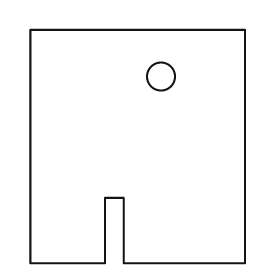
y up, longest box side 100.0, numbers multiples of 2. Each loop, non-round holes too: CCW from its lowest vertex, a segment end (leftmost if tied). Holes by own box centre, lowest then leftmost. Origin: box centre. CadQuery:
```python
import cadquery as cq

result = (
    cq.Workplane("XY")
    .moveTo(-46.0, -50.0)
    .lineTo(-14.0, -50.0)
    .lineTo(-14.0, -22.0)
    .lineTo(-6.0, -22.0)
    .lineTo(-6.0, -50.0)
    .lineTo(46.0, -50.0)
    .lineTo(46.0, 50.0)
    .lineTo(-46.0, 50.0)
    .close()
    .moveTo(10.0, 30.0)
    .circle(6.0)
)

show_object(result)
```